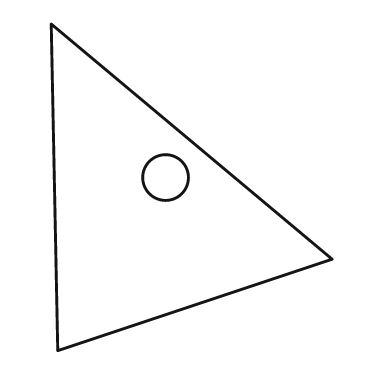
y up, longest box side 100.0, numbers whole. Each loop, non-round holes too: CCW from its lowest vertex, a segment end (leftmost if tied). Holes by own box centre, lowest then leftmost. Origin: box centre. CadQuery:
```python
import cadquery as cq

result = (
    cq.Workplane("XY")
    .moveTo(-41.0, -50.0)
    .lineTo(43.0, -22.0)
    .lineTo(-43.0, 50.0)
    .close()
    .moveTo(-8.0, 3.0)
    .circle(7.0)
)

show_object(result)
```